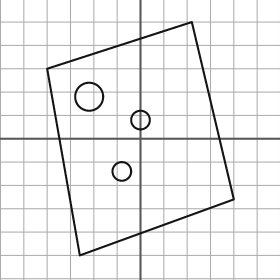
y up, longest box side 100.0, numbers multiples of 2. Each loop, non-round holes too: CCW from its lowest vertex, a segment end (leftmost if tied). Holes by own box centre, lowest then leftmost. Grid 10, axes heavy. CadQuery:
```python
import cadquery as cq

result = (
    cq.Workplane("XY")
    .moveTo(-26.0, -50.0)
    .lineTo(40.0, -26.0)
    .lineTo(22.0, 50.0)
    .lineTo(-40.0, 30.0)
    .close()
    .moveTo(-8.0, -14.0)
    .circle(4.0)
    .moveTo(0.0, 8.0)
    .circle(4.0)
    .moveTo(-22.0, 18.0)
    .circle(6.0)
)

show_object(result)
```